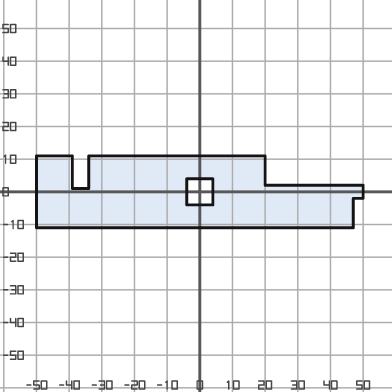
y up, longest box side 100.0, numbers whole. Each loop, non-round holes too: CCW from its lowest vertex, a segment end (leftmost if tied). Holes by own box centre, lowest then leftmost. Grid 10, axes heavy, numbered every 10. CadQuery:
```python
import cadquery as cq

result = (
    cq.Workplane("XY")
    .moveTo(-50.0, -11.0)
    .lineTo(47.0, -11.0)
    .lineTo(47.0, -2.0)
    .lineTo(50.0, -2.0)
    .lineTo(50.0, 2.0)
    .lineTo(20.0, 2.0)
    .lineTo(20.0, 11.0)
    .lineTo(-34.0, 11.0)
    .lineTo(-34.0, 1.0)
    .lineTo(-39.0, 1.0)
    .lineTo(-39.0, 11.0)
    .lineTo(-50.0, 11.0)
    .close()
    .moveTo(-4.0, -4.0)
    .lineTo(4.0, -4.0)
    .lineTo(4.0, 4.0)
    .lineTo(-4.0, 4.0)
    .close()
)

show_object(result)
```